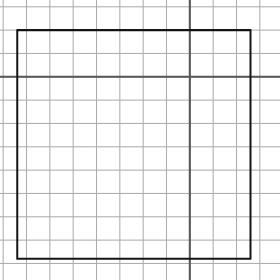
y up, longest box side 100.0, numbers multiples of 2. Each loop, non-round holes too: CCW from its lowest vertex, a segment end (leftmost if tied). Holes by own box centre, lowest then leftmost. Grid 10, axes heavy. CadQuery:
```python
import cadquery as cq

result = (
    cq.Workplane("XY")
    .moveTo(-74.0, -78.0)
    .lineTo(26.0, -78.0)
    .lineTo(26.0, 20.0)
    .lineTo(-74.0, 20.0)
    .close()
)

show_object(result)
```